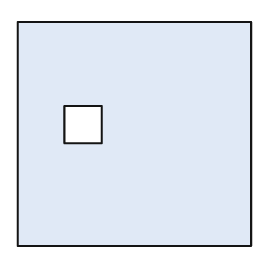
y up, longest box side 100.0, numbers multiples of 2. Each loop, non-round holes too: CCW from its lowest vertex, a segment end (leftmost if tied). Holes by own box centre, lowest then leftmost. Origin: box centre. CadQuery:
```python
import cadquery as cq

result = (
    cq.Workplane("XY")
    .moveTo(-50.0, -48.0)
    .lineTo(50.0, -48.0)
    .lineTo(50.0, 48.0)
    .lineTo(-50.0, 48.0)
    .close()
    .moveTo(-30.0, -4.0)
    .lineTo(-14.0, -4.0)
    .lineTo(-14.0, 12.0)
    .lineTo(-30.0, 12.0)
    .close()
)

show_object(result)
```